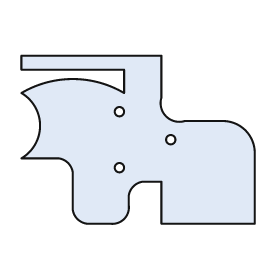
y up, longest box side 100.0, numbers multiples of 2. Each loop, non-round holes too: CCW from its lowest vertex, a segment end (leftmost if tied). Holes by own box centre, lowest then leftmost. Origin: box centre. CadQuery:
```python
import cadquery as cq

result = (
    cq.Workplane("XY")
    .moveTo(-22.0, -36.0)
    .lineTo(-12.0, -36.0)
    .threePointArc((-6.0, -34.0), (-4.0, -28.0))
    .lineTo(-4.0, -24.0)
    .threePointArc((-2.0, -20.0), (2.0, -18.0))
    .lineTo(10.0, -18.0)
    .lineTo(10.0, -36.0)
    .lineTo(50.0, -36.0)
    .lineTo(50.0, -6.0)
    .threePointArc((46.0, 4.0), (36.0, 8.0))
    .lineTo(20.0, 8.0)
    .threePointArc((12.0, 10.0), (10.0, 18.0))
    .lineTo(10.0, 36.0)
    .lineTo(-50.0, 36.0)
    .lineTo(-50.0, 30.0)
    .lineTo(-6.0, 30.0)
    .lineTo(-6.0, 20.0)
    .threePointArc((-28.0, 26.0), (-50.0, 20.0))
    .threePointArc((-42.0, 6.0), (-50.0, -8.0))
    .lineTo(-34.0, -8.0)
    .threePointArc((-30.0, -10.0), (-28.0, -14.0))
    .lineTo(-28.0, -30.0)
    .threePointArc((-26.0, -34.0), (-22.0, -36.0))
    .close()
    .moveTo(-8.0, -12.0)
    .circle(2.0)
    .moveTo(14.0, 0.0)
    .circle(2.0)
    .moveTo(-8.0, 12.0)
    .circle(2.0)
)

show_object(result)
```